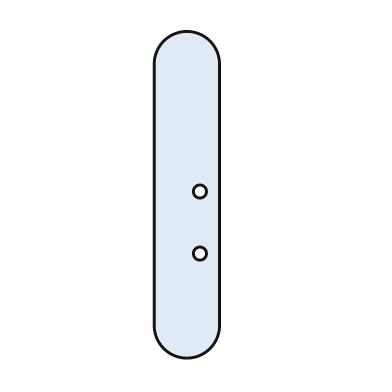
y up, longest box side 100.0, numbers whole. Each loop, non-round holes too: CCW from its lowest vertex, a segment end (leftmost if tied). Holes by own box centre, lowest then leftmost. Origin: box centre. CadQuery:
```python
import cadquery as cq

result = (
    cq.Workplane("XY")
    .moveTo(-10.0, -40.0)
    .threePointArc((0.0, -50.0), (10.0, -40.0))
    .lineTo(10.0, 40.0)
    .threePointArc((0.0, 50.0), (-10.0, 40.0))
    .close()
    .moveTo(4.0, -18.0)
    .circle(2.0)
    .moveTo(4.0, 1.0)
    .circle(2.0)
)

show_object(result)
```